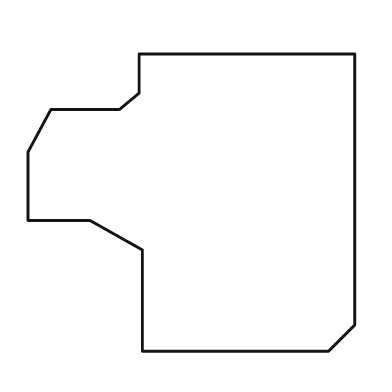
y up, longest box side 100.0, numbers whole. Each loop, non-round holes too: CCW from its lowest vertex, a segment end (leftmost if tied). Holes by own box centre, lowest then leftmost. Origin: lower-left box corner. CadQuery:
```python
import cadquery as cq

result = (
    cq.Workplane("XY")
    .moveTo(35.0, 0.0)
    .lineTo(92.0, 0.0)
    .lineTo(100.0, 8.0)
    .lineTo(100.0, 91.0)
    .lineTo(34.0, 91.0)
    .lineTo(34.0, 79.0)
    .lineTo(28.0, 74.0)
    .lineTo(7.0, 74.0)
    .lineTo(0.0, 61.0)
    .lineTo(0.0, 40.0)
    .lineTo(19.0, 40.0)
    .lineTo(35.0, 31.0)
    .close()
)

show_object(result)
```